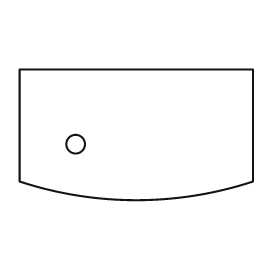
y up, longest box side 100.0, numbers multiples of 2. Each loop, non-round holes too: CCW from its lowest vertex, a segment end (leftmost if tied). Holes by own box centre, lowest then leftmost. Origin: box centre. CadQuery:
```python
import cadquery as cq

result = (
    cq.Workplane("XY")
    .moveTo(-50.0, -20.0)
    .threePointArc((0.0, -28.0), (50.0, -20.0))
    .lineTo(50.0, 28.0)
    .lineTo(-50.0, 28.0)
    .close()
    .moveTo(-26.0, -4.0)
    .circle(4.0)
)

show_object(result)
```